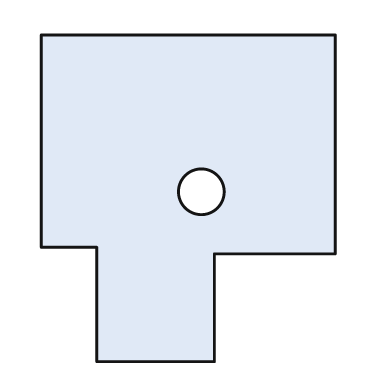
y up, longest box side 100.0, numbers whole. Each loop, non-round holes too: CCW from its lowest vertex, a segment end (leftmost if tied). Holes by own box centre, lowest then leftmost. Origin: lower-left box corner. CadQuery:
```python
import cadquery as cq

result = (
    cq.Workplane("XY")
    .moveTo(17.0, 0.0)
    .lineTo(53.0, 0.0)
    .lineTo(53.0, 33.0)
    .lineTo(90.0, 33.0)
    .lineTo(90.0, 100.0)
    .lineTo(0.0, 100.0)
    .lineTo(0.0, 35.0)
    .lineTo(17.0, 35.0)
    .close()
    .moveTo(49.0, 52.0)
    .circle(7.0)
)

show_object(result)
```